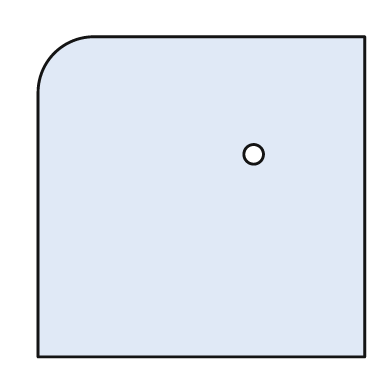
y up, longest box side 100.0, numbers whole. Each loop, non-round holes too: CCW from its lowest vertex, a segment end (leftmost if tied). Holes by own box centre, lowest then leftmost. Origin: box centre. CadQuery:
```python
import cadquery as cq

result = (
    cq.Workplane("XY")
    .moveTo(-50.0, -49.0)
    .lineTo(50.0, -49.0)
    .lineTo(50.0, 49.0)
    .lineTo(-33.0, 49.0)
    .threePointArc((-45.0, 44.0), (-50.0, 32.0))
    .close()
    .moveTo(16.0, 13.0)
    .circle(3.0)
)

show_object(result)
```